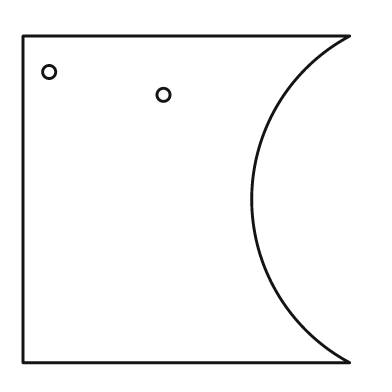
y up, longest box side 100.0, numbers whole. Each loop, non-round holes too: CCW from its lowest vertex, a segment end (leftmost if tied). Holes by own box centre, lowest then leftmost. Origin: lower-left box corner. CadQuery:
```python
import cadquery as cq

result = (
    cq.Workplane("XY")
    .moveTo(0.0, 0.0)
    .lineTo(100.0, 0.0)
    .threePointArc((70.0, 50.0), (100.0, 100.0))
    .lineTo(0.0, 100.0)
    .close()
    .moveTo(43.0, 82.0)
    .circle(2.0)
    .moveTo(8.0, 89.0)
    .circle(2.0)
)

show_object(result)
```